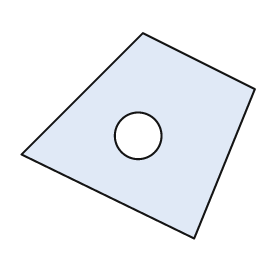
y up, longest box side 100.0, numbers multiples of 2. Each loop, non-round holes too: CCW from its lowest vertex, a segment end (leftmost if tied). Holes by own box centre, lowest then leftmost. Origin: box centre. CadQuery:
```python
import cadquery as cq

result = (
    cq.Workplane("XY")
    .moveTo(24.0, -44.0)
    .lineTo(50.0, 20.0)
    .lineTo(2.0, 44.0)
    .lineTo(-50.0, -8.0)
    .close()
    .moveTo(0.0, 0.0)
    .circle(10.0)
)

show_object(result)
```